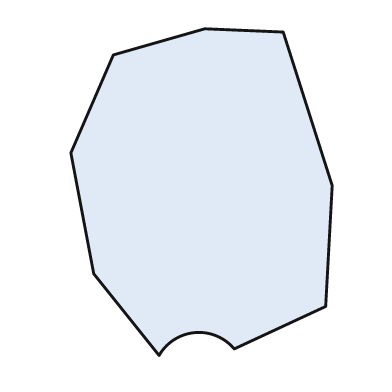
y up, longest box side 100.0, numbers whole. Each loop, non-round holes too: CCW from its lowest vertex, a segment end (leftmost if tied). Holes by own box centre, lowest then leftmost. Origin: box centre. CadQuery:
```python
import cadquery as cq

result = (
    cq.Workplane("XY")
    .moveTo(-13.0, -50.0)
    .threePointArc((-2.0, -43.0), (10.0, -48.0))
    .lineTo(38.0, -35.0)
    .lineTo(40.0, 2.0)
    .lineTo(25.0, 49.0)
    .lineTo(1.0, 50.0)
    .lineTo(-27.0, 42.0)
    .lineTo(-40.0, 12.0)
    .lineTo(-33.0, -25.0)
    .close()
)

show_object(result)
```